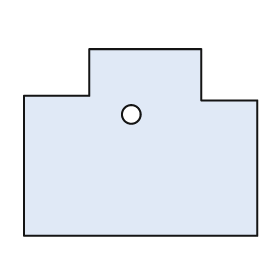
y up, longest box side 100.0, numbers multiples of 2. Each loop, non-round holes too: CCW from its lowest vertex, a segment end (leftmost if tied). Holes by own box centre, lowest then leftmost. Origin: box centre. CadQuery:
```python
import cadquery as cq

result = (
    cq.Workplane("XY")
    .moveTo(-50.0, -40.0)
    .lineTo(50.0, -40.0)
    .lineTo(50.0, 18.0)
    .lineTo(26.0, 18.0)
    .lineTo(26.0, 40.0)
    .lineTo(-22.0, 40.0)
    .lineTo(-22.0, 20.0)
    .lineTo(-50.0, 20.0)
    .close()
    .moveTo(-4.0, 12.0)
    .circle(4.0)
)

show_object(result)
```